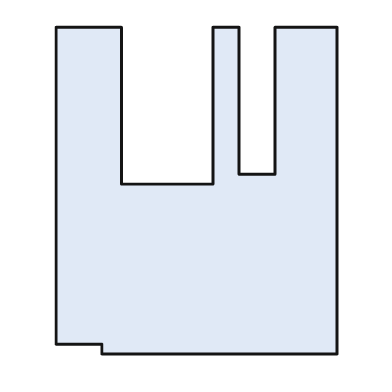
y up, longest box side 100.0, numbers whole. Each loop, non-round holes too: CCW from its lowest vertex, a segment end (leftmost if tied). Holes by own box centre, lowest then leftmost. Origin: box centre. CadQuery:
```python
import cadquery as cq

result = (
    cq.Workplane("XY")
    .moveTo(-29.0, -50.0)
    .lineTo(43.0, -50.0)
    .lineTo(43.0, 50.0)
    .lineTo(24.0, 50.0)
    .lineTo(24.0, 5.0)
    .lineTo(13.0, 5.0)
    .lineTo(13.0, 50.0)
    .lineTo(5.0, 50.0)
    .lineTo(5.0, 2.0)
    .lineTo(-23.0, 2.0)
    .lineTo(-23.0, 50.0)
    .lineTo(-43.0, 50.0)
    .lineTo(-43.0, -47.0)
    .lineTo(-29.0, -47.0)
    .close()
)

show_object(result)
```